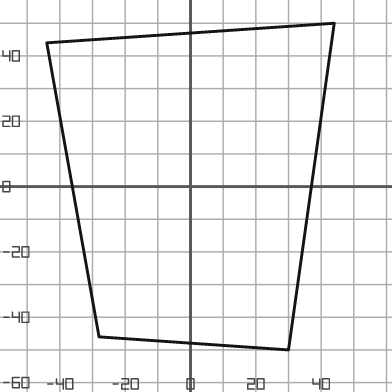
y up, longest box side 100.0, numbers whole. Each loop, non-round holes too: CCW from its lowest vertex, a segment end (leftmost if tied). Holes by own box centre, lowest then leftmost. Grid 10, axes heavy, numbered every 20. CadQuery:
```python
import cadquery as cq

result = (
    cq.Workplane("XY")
    .moveTo(30.0, -50.0)
    .lineTo(44.0, 50.0)
    .lineTo(-44.0, 44.0)
    .lineTo(-28.0, -46.0)
    .close()
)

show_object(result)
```